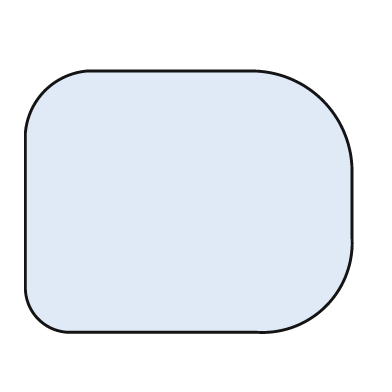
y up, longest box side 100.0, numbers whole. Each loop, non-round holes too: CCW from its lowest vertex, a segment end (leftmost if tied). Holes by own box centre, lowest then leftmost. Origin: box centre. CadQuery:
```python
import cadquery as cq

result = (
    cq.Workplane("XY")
    .moveTo(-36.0, -40.0)
    .lineTo(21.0, -40.0)
    .threePointArc((42.0, -32.0), (50.0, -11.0))
    .lineTo(50.0, 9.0)
    .threePointArc((41.0, 31.0), (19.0, 40.0))
    .lineTo(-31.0, 40.0)
    .threePointArc((-44.0, 34.0), (-50.0, 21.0))
    .lineTo(-50.0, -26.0)
    .threePointArc((-46.0, -36.0), (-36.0, -40.0))
    .close()
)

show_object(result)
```